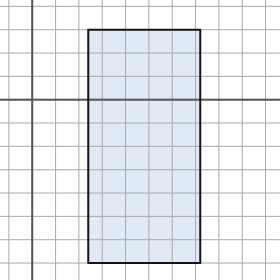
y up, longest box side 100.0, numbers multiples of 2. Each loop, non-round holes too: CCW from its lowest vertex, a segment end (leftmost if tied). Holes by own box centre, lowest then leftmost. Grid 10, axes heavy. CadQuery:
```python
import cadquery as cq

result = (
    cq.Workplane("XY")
    .moveTo(24.0, -70.0)
    .lineTo(72.0, -70.0)
    .lineTo(72.0, 30.0)
    .lineTo(24.0, 30.0)
    .close()
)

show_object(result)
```